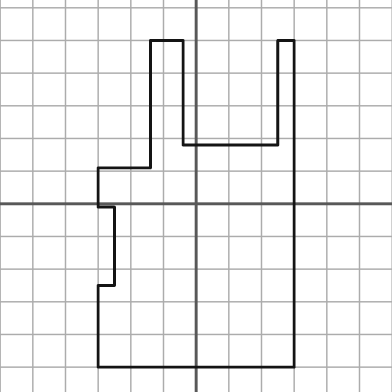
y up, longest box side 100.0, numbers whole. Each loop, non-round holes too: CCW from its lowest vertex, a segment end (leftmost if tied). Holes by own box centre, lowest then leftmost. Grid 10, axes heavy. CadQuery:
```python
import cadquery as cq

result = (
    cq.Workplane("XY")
    .moveTo(-30.0, -50.0)
    .lineTo(30.0, -50.0)
    .lineTo(30.0, 50.0)
    .lineTo(25.0, 50.0)
    .lineTo(25.0, 18.0)
    .lineTo(-4.0, 18.0)
    .lineTo(-4.0, 50.0)
    .lineTo(-14.0, 50.0)
    .lineTo(-14.0, 11.0)
    .lineTo(-30.0, 11.0)
    .lineTo(-30.0, -1.0)
    .lineTo(-25.0, -1.0)
    .lineTo(-25.0, -25.0)
    .lineTo(-30.0, -25.0)
    .close()
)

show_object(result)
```